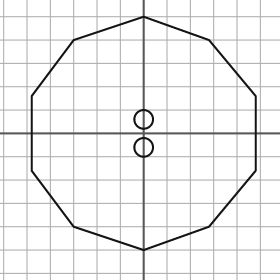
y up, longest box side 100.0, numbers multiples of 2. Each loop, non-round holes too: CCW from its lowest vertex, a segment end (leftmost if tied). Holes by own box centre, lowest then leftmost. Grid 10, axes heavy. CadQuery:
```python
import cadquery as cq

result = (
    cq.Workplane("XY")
    .moveTo(0.0, -50.0)
    .lineTo(28.0, -40.0)
    .lineTo(48.0, -16.0)
    .lineTo(48.0, 16.0)
    .lineTo(28.0, 40.0)
    .lineTo(0.0, 50.0)
    .lineTo(-30.0, 40.0)
    .lineTo(-48.0, 16.0)
    .lineTo(-48.0, -16.0)
    .lineTo(-30.0, -40.0)
    .close()
    .moveTo(0.0, -6.0)
    .circle(4.0)
    .moveTo(0.0, 6.0)
    .circle(4.0)
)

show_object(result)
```